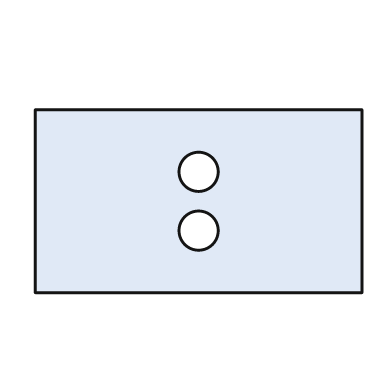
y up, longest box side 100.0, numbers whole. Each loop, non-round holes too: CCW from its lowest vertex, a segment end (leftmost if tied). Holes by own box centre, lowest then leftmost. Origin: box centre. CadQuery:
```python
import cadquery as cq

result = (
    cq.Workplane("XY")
    .moveTo(-50.0, -28.0)
    .lineTo(50.0, -28.0)
    .lineTo(50.0, 28.0)
    .lineTo(-50.0, 28.0)
    .close()
    .moveTo(0.0, -9.0)
    .circle(6.0)
    .moveTo(0.0, 9.0)
    .circle(6.0)
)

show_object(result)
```